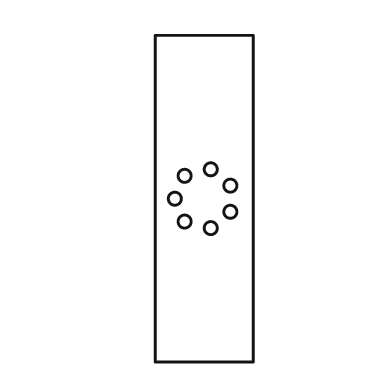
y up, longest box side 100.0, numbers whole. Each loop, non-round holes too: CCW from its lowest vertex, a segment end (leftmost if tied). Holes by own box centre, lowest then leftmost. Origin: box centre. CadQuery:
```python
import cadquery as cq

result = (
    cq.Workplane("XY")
    .moveTo(-15.0, -50.0)
    .lineTo(15.0, -50.0)
    .lineTo(15.0, 50.0)
    .lineTo(-15.0, 50.0)
    .close()
    .moveTo(2.0, -9.0)
    .circle(2.0)
    .moveTo(-6.0, -7.0)
    .circle(2.0)
    .moveTo(8.0, -4.0)
    .circle(2.0)
    .moveTo(-9.0, 0.0)
    .circle(2.0)
    .moveTo(8.0, 4.0)
    .circle(2.0)
    .moveTo(-6.0, 7.0)
    .circle(2.0)
    .moveTo(2.0, 9.0)
    .circle(2.0)
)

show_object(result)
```